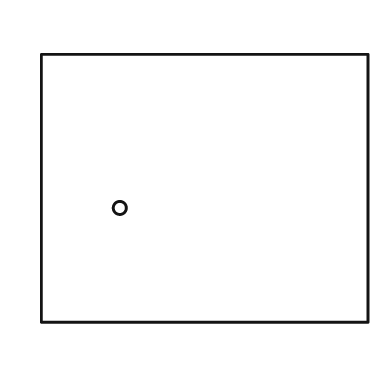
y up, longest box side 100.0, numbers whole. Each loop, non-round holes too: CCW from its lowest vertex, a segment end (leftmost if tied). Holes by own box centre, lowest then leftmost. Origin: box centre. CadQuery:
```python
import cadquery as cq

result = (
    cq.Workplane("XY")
    .moveTo(-50.0, -41.0)
    .lineTo(50.0, -41.0)
    .lineTo(50.0, 41.0)
    .lineTo(-50.0, 41.0)
    .close()
    .moveTo(-26.0, -6.0)
    .circle(2.0)
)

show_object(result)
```